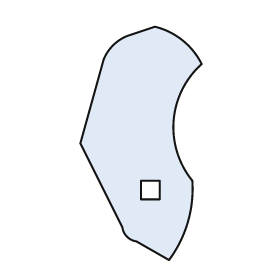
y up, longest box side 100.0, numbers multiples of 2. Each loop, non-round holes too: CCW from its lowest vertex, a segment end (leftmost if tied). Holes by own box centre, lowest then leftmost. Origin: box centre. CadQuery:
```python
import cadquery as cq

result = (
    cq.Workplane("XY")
    .moveTo(12.0, -50.0)
    .threePointArc((20.0, -34.0), (22.0, -16.0))
    .threePointArc((14.0, 10.0), (26.0, 34.0))
    .threePointArc((18.0, 44.0), (6.0, 50.0))
    .lineTo(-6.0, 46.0)
    .threePointArc((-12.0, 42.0), (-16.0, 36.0))
    .lineTo(-26.0, 0.0)
    .lineTo(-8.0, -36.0)
    .threePointArc((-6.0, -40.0), (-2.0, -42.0))
    .close()
    .moveTo(0.0, -24.0)
    .lineTo(8.0, -24.0)
    .lineTo(8.0, -16.0)
    .lineTo(0.0, -16.0)
    .close()
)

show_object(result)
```